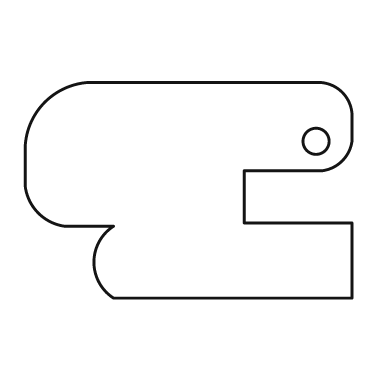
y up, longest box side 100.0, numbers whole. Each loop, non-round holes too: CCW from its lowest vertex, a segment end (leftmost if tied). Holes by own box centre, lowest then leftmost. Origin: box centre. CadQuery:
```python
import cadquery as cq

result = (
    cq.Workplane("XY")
    .moveTo(-23.0, -33.0)
    .lineTo(50.0, -33.0)
    .lineTo(50.0, -10.0)
    .lineTo(17.0, -10.0)
    .lineTo(17.0, 6.0)
    .lineTo(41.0, 6.0)
    .threePointArc((47.0, 9.0), (50.0, 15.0))
    .lineTo(50.0, 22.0)
    .threePointArc((47.0, 30.0), (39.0, 33.0))
    .lineTo(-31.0, 33.0)
    .threePointArc((-44.0, 27.0), (-50.0, 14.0))
    .lineTo(-50.0, 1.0)
    .threePointArc((-46.0, -7.0), (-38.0, -11.0))
    .lineTo(-23.0, -11.0)
    .threePointArc((-29.0, -22.0), (-23.0, -33.0))
    .close()
    .moveTo(39.0, 15.0)
    .circle(4.0)
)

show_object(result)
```